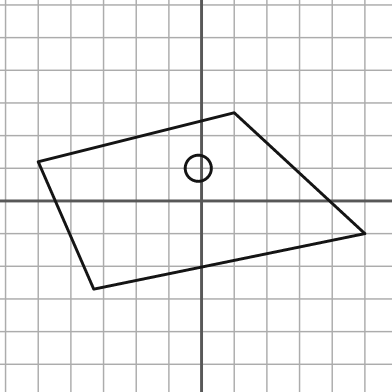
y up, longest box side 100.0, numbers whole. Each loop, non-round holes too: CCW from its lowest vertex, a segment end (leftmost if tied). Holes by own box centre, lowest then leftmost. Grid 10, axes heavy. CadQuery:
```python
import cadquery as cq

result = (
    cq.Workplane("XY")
    .moveTo(-33.0, -27.0)
    .lineTo(50.0, -10.0)
    .lineTo(10.0, 27.0)
    .lineTo(-50.0, 12.0)
    .close()
    .moveTo(-1.0, 10.0)
    .circle(4.0)
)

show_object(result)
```